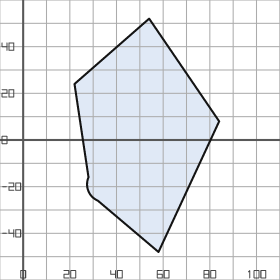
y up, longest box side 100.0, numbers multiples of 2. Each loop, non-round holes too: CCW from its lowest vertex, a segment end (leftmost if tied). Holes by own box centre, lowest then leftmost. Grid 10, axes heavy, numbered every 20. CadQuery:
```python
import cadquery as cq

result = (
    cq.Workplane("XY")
    .moveTo(58.0, -48.0)
    .lineTo(84.0, 8.0)
    .lineTo(54.0, 52.0)
    .lineTo(22.0, 24.0)
    .lineTo(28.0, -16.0)
    .threePointArc((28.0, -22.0), (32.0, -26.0))
    .close()
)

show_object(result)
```